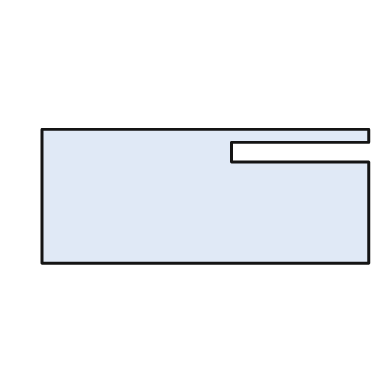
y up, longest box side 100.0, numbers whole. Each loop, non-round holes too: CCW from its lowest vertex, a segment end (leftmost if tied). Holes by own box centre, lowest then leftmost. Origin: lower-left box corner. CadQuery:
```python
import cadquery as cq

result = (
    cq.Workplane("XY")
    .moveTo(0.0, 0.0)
    .lineTo(100.0, 0.0)
    .lineTo(100.0, 31.0)
    .lineTo(58.0, 31.0)
    .lineTo(58.0, 37.0)
    .lineTo(100.0, 37.0)
    .lineTo(100.0, 41.0)
    .lineTo(0.0, 41.0)
    .close()
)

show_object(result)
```